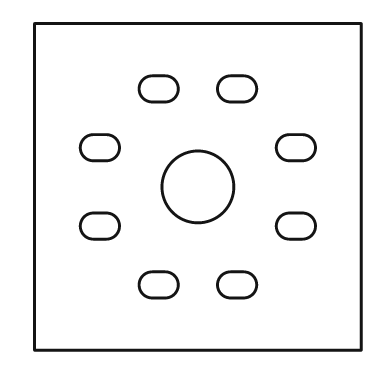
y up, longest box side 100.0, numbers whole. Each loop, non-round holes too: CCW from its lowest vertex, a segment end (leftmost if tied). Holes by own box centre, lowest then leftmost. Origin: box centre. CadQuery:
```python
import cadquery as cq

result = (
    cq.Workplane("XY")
    .moveTo(-50.0, -50.0)
    .lineTo(50.0, -50.0)
    .lineTo(50.0, 50.0)
    .lineTo(-50.0, 50.0)
    .close()
    .moveTo(-14.0, -34.0)
    .lineTo(-10.0, -34.0)
    .threePointArc((-6.0, -30.0), (-10.0, -26.0))
    .lineTo(-14.0, -26.0)
    .threePointArc((-18.0, -30.0), (-14.0, -34.0))
    .close()
    .moveTo(10.0, -34.0)
    .lineTo(14.0, -34.0)
    .threePointArc((18.0, -30.0), (14.0, -26.0))
    .lineTo(10.0, -26.0)
    .threePointArc((6.0, -30.0), (10.0, -34.0))
    .close()
    .moveTo(-32.0, -16.0)
    .lineTo(-28.0, -16.0)
    .threePointArc((-24.0, -12.0), (-28.0, -8.0))
    .lineTo(-32.0, -8.0)
    .threePointArc((-36.0, -12.0), (-32.0, -16.0))
    .close()
    .moveTo(28.0, -16.0)
    .lineTo(32.0, -16.0)
    .threePointArc((36.0, -12.0), (32.0, -8.0))
    .lineTo(28.0, -8.0)
    .threePointArc((24.0, -12.0), (28.0, -16.0))
    .close()
    .moveTo(0.0, 0.0)
    .circle(11.0)
    .moveTo(-32.0, 8.0)
    .lineTo(-28.0, 8.0)
    .threePointArc((-24.0, 12.0), (-28.0, 16.0))
    .lineTo(-32.0, 16.0)
    .threePointArc((-36.0, 12.0), (-32.0, 8.0))
    .close()
    .moveTo(28.0, 8.0)
    .lineTo(32.0, 8.0)
    .threePointArc((36.0, 12.0), (32.0, 16.0))
    .lineTo(28.0, 16.0)
    .threePointArc((24.0, 12.0), (28.0, 8.0))
    .close()
    .moveTo(-14.0, 26.0)
    .lineTo(-10.0, 26.0)
    .threePointArc((-6.0, 30.0), (-10.0, 34.0))
    .lineTo(-14.0, 34.0)
    .threePointArc((-18.0, 30.0), (-14.0, 26.0))
    .close()
    .moveTo(10.0, 26.0)
    .lineTo(14.0, 26.0)
    .threePointArc((18.0, 30.0), (14.0, 34.0))
    .lineTo(10.0, 34.0)
    .threePointArc((6.0, 30.0), (10.0, 26.0))
    .close()
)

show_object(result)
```